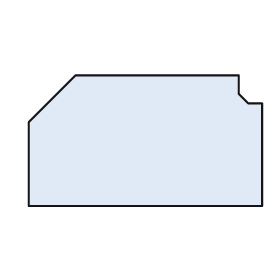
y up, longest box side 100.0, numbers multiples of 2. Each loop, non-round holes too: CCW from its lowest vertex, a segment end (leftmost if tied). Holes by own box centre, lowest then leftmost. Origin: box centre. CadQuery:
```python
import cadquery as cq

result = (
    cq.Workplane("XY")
    .moveTo(-50.0, -28.0)
    .lineTo(50.0, -28.0)
    .lineTo(50.0, 16.0)
    .lineTo(44.0, 16.0)
    .lineTo(40.0, 20.0)
    .lineTo(40.0, 28.0)
    .lineTo(-30.0, 28.0)
    .lineTo(-50.0, 8.0)
    .close()
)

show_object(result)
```